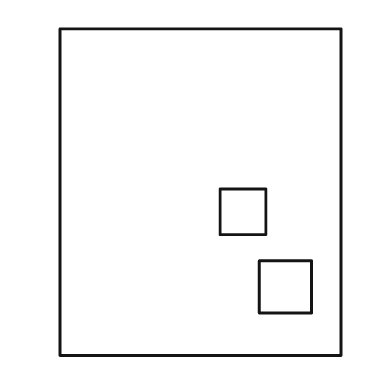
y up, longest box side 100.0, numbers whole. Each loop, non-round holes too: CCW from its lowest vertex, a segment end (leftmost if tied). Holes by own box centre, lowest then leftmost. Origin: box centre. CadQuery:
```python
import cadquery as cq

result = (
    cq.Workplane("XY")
    .moveTo(-43.0, -50.0)
    .lineTo(43.0, -50.0)
    .lineTo(43.0, 50.0)
    .lineTo(-43.0, 50.0)
    .close()
    .moveTo(18.0, -37.0)
    .lineTo(34.0, -37.0)
    .lineTo(34.0, -21.0)
    .lineTo(18.0, -21.0)
    .close()
    .moveTo(6.0, -13.0)
    .lineTo(20.0, -13.0)
    .lineTo(20.0, 1.0)
    .lineTo(6.0, 1.0)
    .close()
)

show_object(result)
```